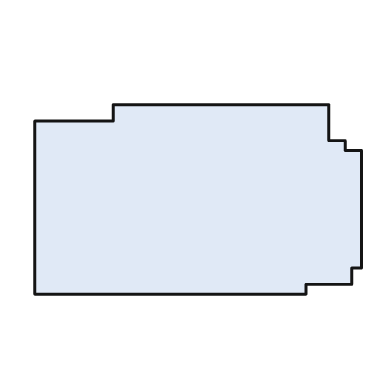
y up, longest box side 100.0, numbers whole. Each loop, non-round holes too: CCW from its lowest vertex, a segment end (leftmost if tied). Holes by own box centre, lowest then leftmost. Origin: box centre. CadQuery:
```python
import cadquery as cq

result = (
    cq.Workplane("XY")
    .moveTo(-50.0, -29.0)
    .lineTo(33.0, -29.0)
    .lineTo(33.0, -26.0)
    .lineTo(47.0, -26.0)
    .lineTo(47.0, -21.0)
    .lineTo(50.0, -21.0)
    .lineTo(50.0, 15.0)
    .lineTo(45.0, 15.0)
    .lineTo(45.0, 18.0)
    .lineTo(40.0, 18.0)
    .lineTo(40.0, 29.0)
    .lineTo(-26.0, 29.0)
    .lineTo(-26.0, 24.0)
    .lineTo(-50.0, 24.0)
    .close()
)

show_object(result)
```